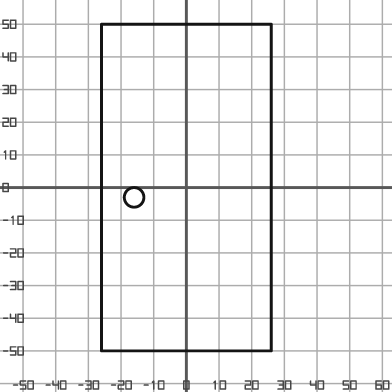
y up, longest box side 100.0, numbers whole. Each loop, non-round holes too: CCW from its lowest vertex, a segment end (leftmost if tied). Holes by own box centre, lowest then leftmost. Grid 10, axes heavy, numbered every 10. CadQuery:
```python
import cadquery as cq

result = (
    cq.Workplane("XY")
    .moveTo(-26.0, -50.0)
    .lineTo(26.0, -50.0)
    .lineTo(26.0, 50.0)
    .lineTo(-26.0, 50.0)
    .close()
    .moveTo(-16.0, -3.0)
    .circle(3.0)
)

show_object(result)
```